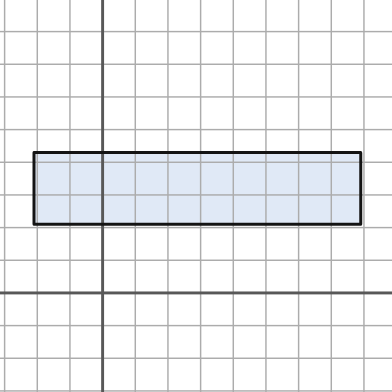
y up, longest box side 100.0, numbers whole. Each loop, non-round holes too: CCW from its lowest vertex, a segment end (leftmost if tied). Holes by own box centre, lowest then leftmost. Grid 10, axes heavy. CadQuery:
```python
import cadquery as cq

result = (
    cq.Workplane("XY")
    .moveTo(-21.0, 21.0)
    .lineTo(79.0, 21.0)
    .lineTo(79.0, 43.0)
    .lineTo(-21.0, 43.0)
    .close()
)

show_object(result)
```